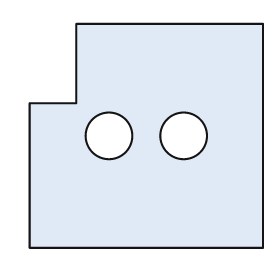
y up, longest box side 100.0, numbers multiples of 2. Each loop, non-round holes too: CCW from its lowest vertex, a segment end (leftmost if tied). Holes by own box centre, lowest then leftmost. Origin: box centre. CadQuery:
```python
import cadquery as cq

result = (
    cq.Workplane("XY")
    .moveTo(-50.0, -48.0)
    .lineTo(50.0, -48.0)
    .lineTo(50.0, 48.0)
    .lineTo(-30.0, 48.0)
    .lineTo(-30.0, 14.0)
    .lineTo(-50.0, 14.0)
    .close()
    .moveTo(-16.0, 0.0)
    .circle(10.0)
    .moveTo(16.0, 0.0)
    .circle(10.0)
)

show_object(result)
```